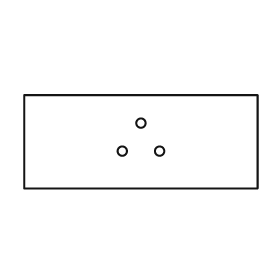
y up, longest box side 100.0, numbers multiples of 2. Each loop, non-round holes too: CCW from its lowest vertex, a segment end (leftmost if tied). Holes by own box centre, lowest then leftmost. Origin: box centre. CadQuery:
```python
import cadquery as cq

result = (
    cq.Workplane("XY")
    .moveTo(-50.0, -20.0)
    .lineTo(50.0, -20.0)
    .lineTo(50.0, 20.0)
    .lineTo(-50.0, 20.0)
    .close()
    .moveTo(-8.0, -4.0)
    .circle(2.0)
    .moveTo(8.0, -4.0)
    .circle(2.0)
    .moveTo(0.0, 8.0)
    .circle(2.0)
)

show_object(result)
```